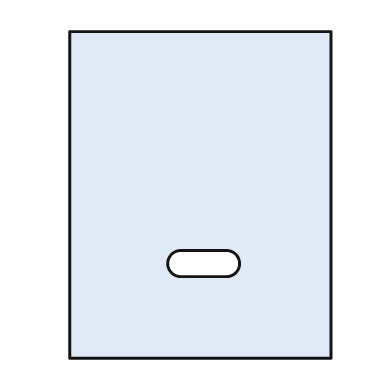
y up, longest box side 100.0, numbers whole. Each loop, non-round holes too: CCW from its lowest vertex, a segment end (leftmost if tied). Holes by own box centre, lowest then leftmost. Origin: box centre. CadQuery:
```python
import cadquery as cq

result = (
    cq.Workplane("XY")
    .moveTo(-40.0, -50.0)
    .lineTo(40.0, -50.0)
    .lineTo(40.0, 50.0)
    .lineTo(-40.0, 50.0)
    .close()
    .moveTo(-6.0, -25.0)
    .lineTo(8.0, -25.0)
    .threePointArc((12.0, -21.0), (8.0, -17.0))
    .lineTo(-6.0, -17.0)
    .threePointArc((-10.0, -21.0), (-6.0, -25.0))
    .close()
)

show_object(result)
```